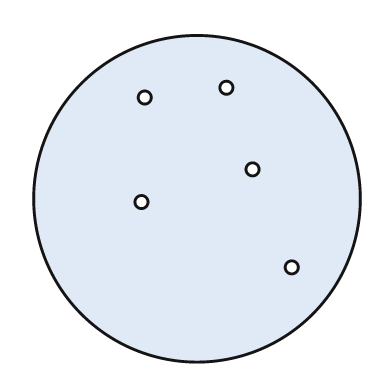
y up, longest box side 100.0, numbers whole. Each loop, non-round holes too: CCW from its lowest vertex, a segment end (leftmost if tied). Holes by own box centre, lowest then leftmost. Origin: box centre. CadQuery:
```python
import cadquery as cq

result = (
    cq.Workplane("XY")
    .moveTo(0.0, 0.0)
    .circle(50.0)
    .moveTo(29.0, -21.0)
    .circle(2.0)
    .moveTo(-17.0, -1.0)
    .circle(2.0)
    .moveTo(17.0, 9.0)
    .circle(2.0)
    .moveTo(-16.0, 31.0)
    .circle(2.0)
    .moveTo(9.0, 34.0)
    .circle(2.0)
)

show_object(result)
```